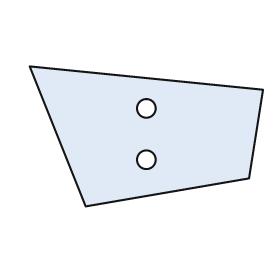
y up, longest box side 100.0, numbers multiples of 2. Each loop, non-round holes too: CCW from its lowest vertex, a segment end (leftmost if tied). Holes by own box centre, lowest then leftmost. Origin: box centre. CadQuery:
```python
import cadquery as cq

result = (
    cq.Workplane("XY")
    .moveTo(-26.0, -30.0)
    .lineTo(44.0, -18.0)
    .lineTo(50.0, 20.0)
    .lineTo(-50.0, 30.0)
    .close()
    .moveTo(0.0, -10.0)
    .circle(4.0)
    .moveTo(0.0, 12.0)
    .circle(4.0)
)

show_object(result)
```